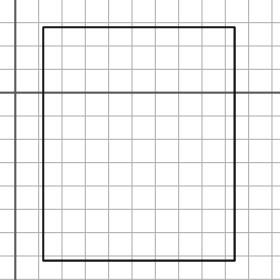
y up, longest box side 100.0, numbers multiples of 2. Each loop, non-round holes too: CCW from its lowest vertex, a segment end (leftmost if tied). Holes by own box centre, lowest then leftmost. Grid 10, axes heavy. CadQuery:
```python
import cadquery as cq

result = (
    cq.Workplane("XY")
    .moveTo(12.0, -72.0)
    .lineTo(94.0, -72.0)
    .lineTo(94.0, 28.0)
    .lineTo(12.0, 28.0)
    .close()
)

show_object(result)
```